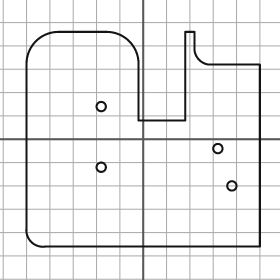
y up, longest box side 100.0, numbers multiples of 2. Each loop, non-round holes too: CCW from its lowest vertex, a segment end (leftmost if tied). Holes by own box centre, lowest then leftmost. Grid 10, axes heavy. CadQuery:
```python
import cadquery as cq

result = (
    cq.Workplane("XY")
    .moveTo(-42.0, -46.0)
    .lineTo(50.0, -46.0)
    .lineTo(50.0, 32.0)
    .lineTo(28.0, 32.0)
    .threePointArc((24.0, 34.0), (22.0, 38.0))
    .lineTo(22.0, 46.0)
    .lineTo(18.0, 46.0)
    .lineTo(18.0, 8.0)
    .lineTo(-2.0, 8.0)
    .lineTo(-2.0, 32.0)
    .threePointArc((-6.0, 42.0), (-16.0, 46.0))
    .lineTo(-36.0, 46.0)
    .threePointArc((-46.0, 42.0), (-50.0, 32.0))
    .lineTo(-50.0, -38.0)
    .threePointArc((-48.0, -44.0), (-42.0, -46.0))
    .close()
    .moveTo(38.0, -20.0)
    .circle(2.0)
    .moveTo(-18.0, -12.0)
    .circle(2.0)
    .moveTo(32.0, -4.0)
    .circle(2.0)
    .moveTo(-18.0, 14.0)
    .circle(2.0)
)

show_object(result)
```